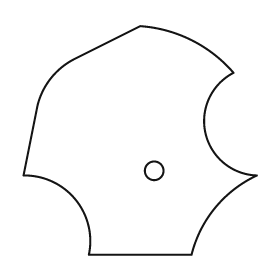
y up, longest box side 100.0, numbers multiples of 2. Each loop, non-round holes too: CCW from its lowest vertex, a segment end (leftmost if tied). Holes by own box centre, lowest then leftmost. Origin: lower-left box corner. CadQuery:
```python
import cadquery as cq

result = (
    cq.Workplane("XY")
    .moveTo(28.0, 0.0)
    .lineTo(72.0, 0.0)
    .threePointArc((82.0, 20.0), (100.0, 34.0))
    .threePointArc((78.0, 52.0), (90.0, 78.0))
    .threePointArc((72.0, 92.0), (50.0, 98.0))
    .lineTo(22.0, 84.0)
    .threePointArc((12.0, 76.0), (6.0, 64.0))
    .lineTo(0.0, 34.0)
    .threePointArc((22.0, 24.0), (28.0, 0.0))
    .close()
    .moveTo(56.0, 36.0)
    .circle(4.0)
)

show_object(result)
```